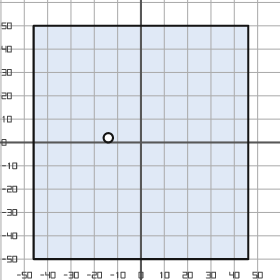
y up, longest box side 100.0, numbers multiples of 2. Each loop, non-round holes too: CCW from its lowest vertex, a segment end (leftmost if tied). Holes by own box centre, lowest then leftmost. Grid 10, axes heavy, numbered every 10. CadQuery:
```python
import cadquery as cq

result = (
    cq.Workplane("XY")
    .moveTo(-46.0, -50.0)
    .lineTo(46.0, -50.0)
    .lineTo(46.0, 50.0)
    .lineTo(-46.0, 50.0)
    .close()
    .moveTo(-14.0, 2.0)
    .circle(2.0)
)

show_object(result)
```